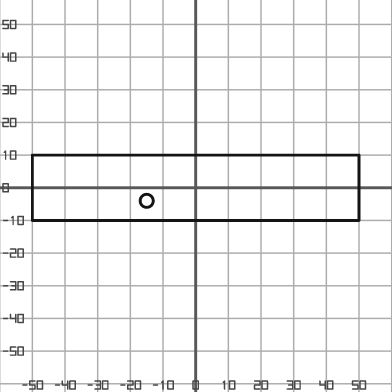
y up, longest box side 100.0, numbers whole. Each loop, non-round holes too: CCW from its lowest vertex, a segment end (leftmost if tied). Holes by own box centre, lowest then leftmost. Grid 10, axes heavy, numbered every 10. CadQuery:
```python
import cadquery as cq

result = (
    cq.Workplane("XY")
    .moveTo(-50.0, -10.0)
    .lineTo(50.0, -10.0)
    .lineTo(50.0, 10.0)
    .lineTo(-50.0, 10.0)
    .close()
    .moveTo(-15.0, -4.0)
    .circle(2.0)
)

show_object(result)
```